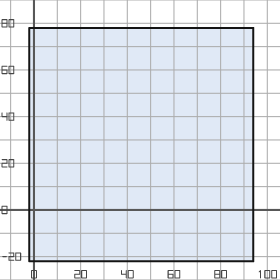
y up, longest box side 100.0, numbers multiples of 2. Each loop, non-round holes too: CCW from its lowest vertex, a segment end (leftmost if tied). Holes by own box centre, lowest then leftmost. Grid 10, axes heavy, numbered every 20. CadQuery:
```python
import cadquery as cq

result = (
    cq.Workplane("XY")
    .moveTo(-2.0, -22.0)
    .lineTo(94.0, -22.0)
    .lineTo(94.0, 78.0)
    .lineTo(-2.0, 78.0)
    .close()
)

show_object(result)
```